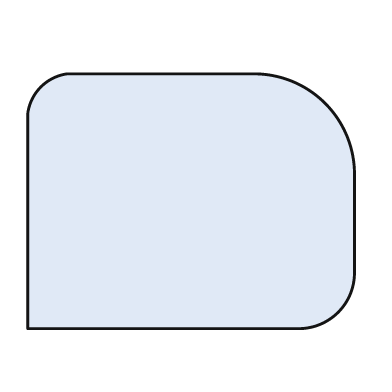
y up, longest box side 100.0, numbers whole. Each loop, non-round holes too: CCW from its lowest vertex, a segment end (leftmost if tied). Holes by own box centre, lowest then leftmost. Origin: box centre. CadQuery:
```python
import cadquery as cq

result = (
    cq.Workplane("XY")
    .moveTo(-50.0, -39.0)
    .lineTo(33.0, -39.0)
    .threePointArc((45.0, -34.0), (50.0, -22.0))
    .lineTo(50.0, 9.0)
    .threePointArc((41.0, 30.0), (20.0, 39.0))
    .lineTo(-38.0, 39.0)
    .threePointArc((-46.0, 35.0), (-50.0, 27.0))
    .close()
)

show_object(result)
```